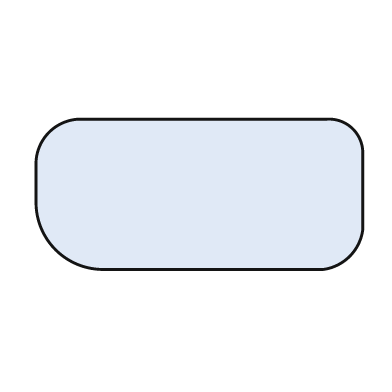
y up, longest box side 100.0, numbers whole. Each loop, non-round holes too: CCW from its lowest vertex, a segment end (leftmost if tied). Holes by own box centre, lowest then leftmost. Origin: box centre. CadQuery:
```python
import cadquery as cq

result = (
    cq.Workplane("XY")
    .moveTo(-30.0, -23.0)
    .lineTo(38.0, -23.0)
    .threePointArc((46.0, -19.0), (50.0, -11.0))
    .lineTo(50.0, 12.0)
    .threePointArc((47.0, 20.0), (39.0, 23.0))
    .lineTo(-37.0, 23.0)
    .threePointArc((-46.0, 19.0), (-50.0, 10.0))
    .lineTo(-50.0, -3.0)
    .threePointArc((-44.0, -17.0), (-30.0, -23.0))
    .close()
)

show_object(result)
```